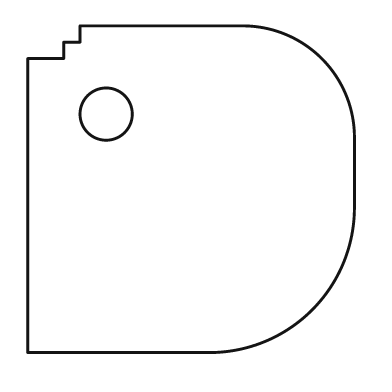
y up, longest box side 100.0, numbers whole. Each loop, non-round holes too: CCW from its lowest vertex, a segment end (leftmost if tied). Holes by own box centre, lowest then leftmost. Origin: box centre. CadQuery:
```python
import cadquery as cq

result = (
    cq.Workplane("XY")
    .moveTo(-50.0, -50.0)
    .lineTo(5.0, -50.0)
    .threePointArc((37.0, -37.0), (50.0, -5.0))
    .lineTo(50.0, 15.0)
    .threePointArc((40.0, 40.0), (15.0, 50.0))
    .lineTo(-34.0, 50.0)
    .lineTo(-34.0, 45.0)
    .lineTo(-39.0, 45.0)
    .lineTo(-39.0, 40.0)
    .lineTo(-50.0, 40.0)
    .close()
    .moveTo(-26.0, 23.0)
    .circle(8.0)
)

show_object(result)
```